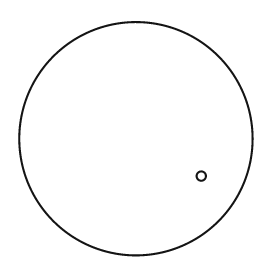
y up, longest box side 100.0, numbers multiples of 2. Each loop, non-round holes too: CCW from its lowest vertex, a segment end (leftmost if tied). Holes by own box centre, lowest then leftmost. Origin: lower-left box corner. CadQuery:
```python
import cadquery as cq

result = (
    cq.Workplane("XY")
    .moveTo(50.0, 50.0)
    .circle(50.0)
    .moveTo(78.0, 34.0)
    .circle(2.0)
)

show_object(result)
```